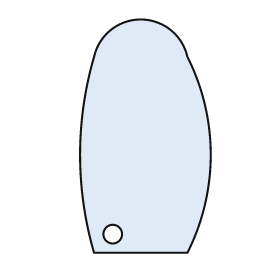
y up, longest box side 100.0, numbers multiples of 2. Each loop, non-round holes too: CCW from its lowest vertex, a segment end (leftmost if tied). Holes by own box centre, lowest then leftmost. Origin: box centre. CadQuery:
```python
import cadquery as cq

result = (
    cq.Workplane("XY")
    .moveTo(-22.0, -50.0)
    .lineTo(18.0, -50.0)
    .threePointArc((28.0, -8.0), (18.0, 34.0))
    .threePointArc((-2.0, 50.0), (-22.0, 34.0))
    .threePointArc((-28.0, -8.0), (-22.0, -50.0))
    .close()
    .moveTo(-14.0, -42.0)
    .circle(4.0)
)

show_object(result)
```